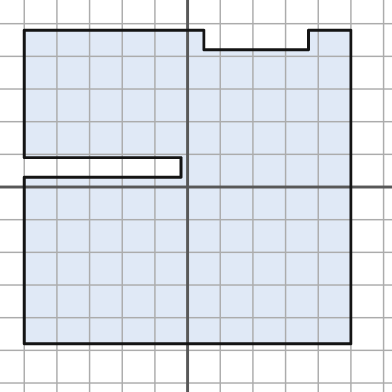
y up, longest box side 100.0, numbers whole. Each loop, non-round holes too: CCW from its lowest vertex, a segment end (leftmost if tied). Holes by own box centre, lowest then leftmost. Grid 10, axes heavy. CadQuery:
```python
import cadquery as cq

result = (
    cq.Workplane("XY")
    .moveTo(-50.0, -48.0)
    .lineTo(50.0, -48.0)
    .lineTo(50.0, 48.0)
    .lineTo(37.0, 48.0)
    .lineTo(37.0, 42.0)
    .lineTo(5.0, 42.0)
    .lineTo(5.0, 48.0)
    .lineTo(-50.0, 48.0)
    .lineTo(-50.0, 9.0)
    .lineTo(-2.0, 9.0)
    .lineTo(-2.0, 3.0)
    .lineTo(-50.0, 3.0)
    .close()
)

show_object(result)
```